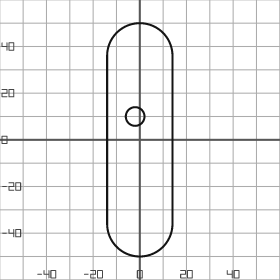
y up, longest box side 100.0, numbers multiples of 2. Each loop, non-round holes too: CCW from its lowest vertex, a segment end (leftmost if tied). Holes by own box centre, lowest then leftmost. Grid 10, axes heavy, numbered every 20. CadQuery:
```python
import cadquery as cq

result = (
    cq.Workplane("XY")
    .moveTo(-14.0, -36.0)
    .threePointArc((0.0, -50.0), (14.0, -36.0))
    .lineTo(14.0, 36.0)
    .threePointArc((0.0, 50.0), (-14.0, 36.0))
    .close()
    .moveTo(-2.0, 10.0)
    .circle(4.0)
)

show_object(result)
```